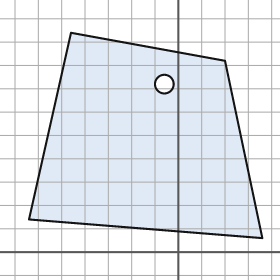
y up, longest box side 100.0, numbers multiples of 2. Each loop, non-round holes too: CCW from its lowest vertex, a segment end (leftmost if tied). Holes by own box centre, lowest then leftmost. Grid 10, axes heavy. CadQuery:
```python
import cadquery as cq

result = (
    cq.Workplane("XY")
    .moveTo(36.0, 6.0)
    .lineTo(20.0, 82.0)
    .lineTo(-46.0, 94.0)
    .lineTo(-64.0, 14.0)
    .close()
    .moveTo(-6.0, 72.0)
    .circle(4.0)
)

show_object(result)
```